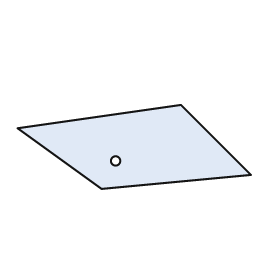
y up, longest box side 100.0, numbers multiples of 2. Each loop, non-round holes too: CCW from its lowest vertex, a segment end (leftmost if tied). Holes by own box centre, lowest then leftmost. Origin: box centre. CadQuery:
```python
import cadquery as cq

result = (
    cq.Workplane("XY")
    .moveTo(-14.0, -18.0)
    .lineTo(50.0, -12.0)
    .lineTo(20.0, 18.0)
    .lineTo(-50.0, 8.0)
    .close()
    .moveTo(-8.0, -6.0)
    .circle(2.0)
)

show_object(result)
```